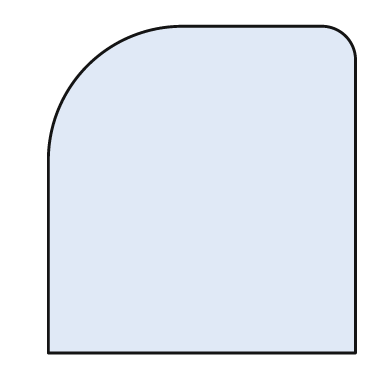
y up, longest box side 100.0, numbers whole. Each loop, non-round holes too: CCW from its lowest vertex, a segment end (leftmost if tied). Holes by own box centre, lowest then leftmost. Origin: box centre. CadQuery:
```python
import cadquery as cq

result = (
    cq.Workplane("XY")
    .moveTo(-47.0, -50.0)
    .lineTo(47.0, -50.0)
    .lineTo(47.0, 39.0)
    .threePointArc((44.0, 47.0), (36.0, 50.0))
    .lineTo(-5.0, 50.0)
    .threePointArc((-35.0, 38.0), (-47.0, 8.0))
    .close()
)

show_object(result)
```